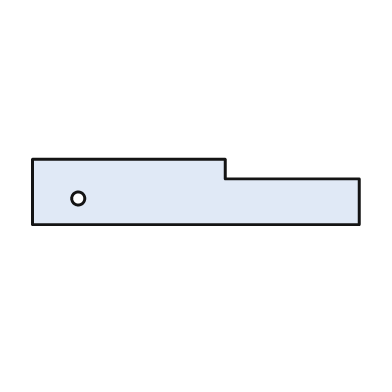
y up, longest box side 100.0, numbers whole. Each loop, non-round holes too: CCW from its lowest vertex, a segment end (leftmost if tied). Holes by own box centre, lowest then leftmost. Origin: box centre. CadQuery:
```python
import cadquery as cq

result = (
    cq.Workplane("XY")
    .moveTo(-50.0, -10.0)
    .lineTo(50.0, -10.0)
    .lineTo(50.0, 4.0)
    .lineTo(9.0, 4.0)
    .lineTo(9.0, 10.0)
    .lineTo(-50.0, 10.0)
    .close()
    .moveTo(-36.0, -2.0)
    .circle(2.0)
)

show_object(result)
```